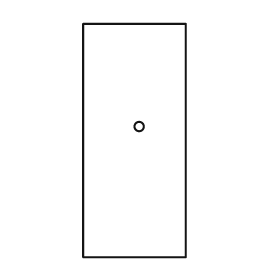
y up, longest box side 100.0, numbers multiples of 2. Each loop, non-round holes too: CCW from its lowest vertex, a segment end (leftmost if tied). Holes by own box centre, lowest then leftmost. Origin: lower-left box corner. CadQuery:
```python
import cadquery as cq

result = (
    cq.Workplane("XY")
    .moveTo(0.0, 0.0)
    .lineTo(44.0, 0.0)
    .lineTo(44.0, 100.0)
    .lineTo(0.0, 100.0)
    .close()
    .moveTo(24.0, 56.0)
    .circle(2.0)
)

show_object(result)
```